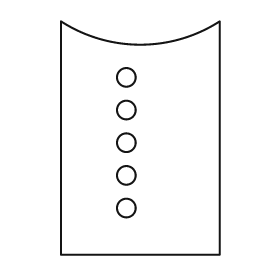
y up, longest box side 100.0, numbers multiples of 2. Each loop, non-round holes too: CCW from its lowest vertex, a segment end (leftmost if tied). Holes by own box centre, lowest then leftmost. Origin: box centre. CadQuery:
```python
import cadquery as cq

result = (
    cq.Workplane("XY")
    .moveTo(-34.0, -50.0)
    .lineTo(34.0, -50.0)
    .lineTo(34.0, 50.0)
    .threePointArc((0.0, 40.0), (-34.0, 50.0))
    .close()
    .moveTo(-6.0, -30.0)
    .circle(4.0)
    .moveTo(-6.0, -16.0)
    .circle(4.0)
    .moveTo(-6.0, -2.0)
    .circle(4.0)
    .moveTo(-6.0, 12.0)
    .circle(4.0)
    .moveTo(-6.0, 26.0)
    .circle(4.0)
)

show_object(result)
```